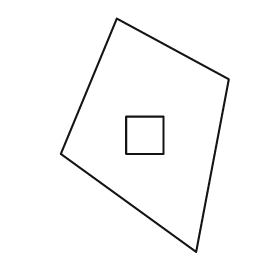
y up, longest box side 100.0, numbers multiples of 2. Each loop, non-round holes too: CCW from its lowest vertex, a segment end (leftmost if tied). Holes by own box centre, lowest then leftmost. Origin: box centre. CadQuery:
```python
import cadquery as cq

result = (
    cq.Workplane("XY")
    .moveTo(22.0, -50.0)
    .lineTo(36.0, 24.0)
    .lineTo(-12.0, 50.0)
    .lineTo(-36.0, -8.0)
    .close()
    .moveTo(-8.0, -8.0)
    .lineTo(8.0, -8.0)
    .lineTo(8.0, 8.0)
    .lineTo(-8.0, 8.0)
    .close()
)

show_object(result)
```